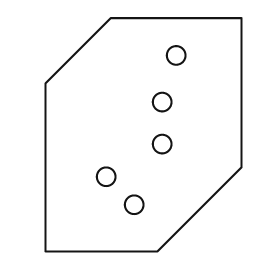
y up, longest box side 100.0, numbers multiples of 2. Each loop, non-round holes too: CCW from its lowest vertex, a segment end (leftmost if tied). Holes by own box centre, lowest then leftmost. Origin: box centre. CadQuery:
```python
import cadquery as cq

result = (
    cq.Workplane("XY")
    .moveTo(-42.0, -50.0)
    .lineTo(6.0, -50.0)
    .lineTo(42.0, -14.0)
    .lineTo(42.0, 50.0)
    .lineTo(-14.0, 50.0)
    .lineTo(-42.0, 22.0)
    .close()
    .moveTo(-4.0, -30.0)
    .circle(4.0)
    .moveTo(-16.0, -18.0)
    .circle(4.0)
    .moveTo(8.0, -4.0)
    .circle(4.0)
    .moveTo(8.0, 14.0)
    .circle(4.0)
    .moveTo(14.0, 34.0)
    .circle(4.0)
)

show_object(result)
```